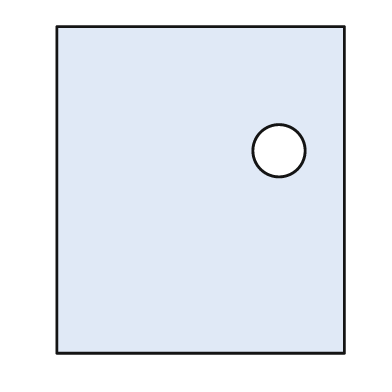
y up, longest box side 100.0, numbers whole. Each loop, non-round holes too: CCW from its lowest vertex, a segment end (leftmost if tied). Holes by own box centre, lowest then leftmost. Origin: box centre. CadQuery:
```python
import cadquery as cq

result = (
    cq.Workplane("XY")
    .moveTo(-44.0, -50.0)
    .lineTo(44.0, -50.0)
    .lineTo(44.0, 50.0)
    .lineTo(-44.0, 50.0)
    .close()
    .moveTo(24.0, 12.0)
    .circle(8.0)
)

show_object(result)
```